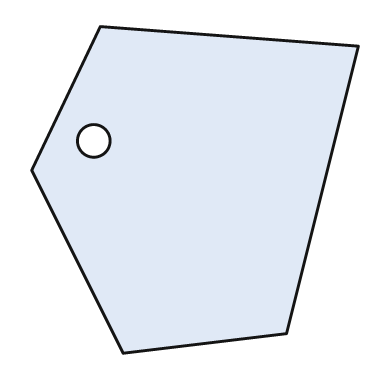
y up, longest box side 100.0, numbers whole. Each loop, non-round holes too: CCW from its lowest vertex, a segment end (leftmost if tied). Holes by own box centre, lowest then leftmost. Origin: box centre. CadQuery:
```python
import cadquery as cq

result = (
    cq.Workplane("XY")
    .moveTo(-22.0, -50.0)
    .lineTo(28.0, -44.0)
    .lineTo(50.0, 44.0)
    .lineTo(-29.0, 50.0)
    .lineTo(-50.0, 6.0)
    .close()
    .moveTo(-31.0, 15.0)
    .circle(5.0)
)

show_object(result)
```